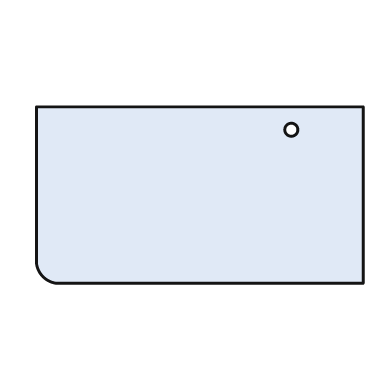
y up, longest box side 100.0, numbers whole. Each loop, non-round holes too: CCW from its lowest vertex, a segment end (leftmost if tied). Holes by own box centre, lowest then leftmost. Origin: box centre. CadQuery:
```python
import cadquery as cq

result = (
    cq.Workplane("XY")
    .moveTo(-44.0, -27.0)
    .lineTo(50.0, -27.0)
    .lineTo(50.0, 27.0)
    .lineTo(-50.0, 27.0)
    .lineTo(-50.0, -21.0)
    .threePointArc((-48.0, -25.0), (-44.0, -27.0))
    .close()
    .moveTo(28.0, 20.0)
    .circle(2.0)
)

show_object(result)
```